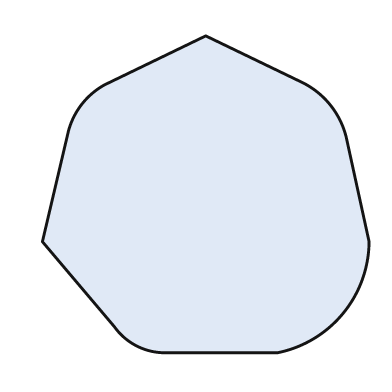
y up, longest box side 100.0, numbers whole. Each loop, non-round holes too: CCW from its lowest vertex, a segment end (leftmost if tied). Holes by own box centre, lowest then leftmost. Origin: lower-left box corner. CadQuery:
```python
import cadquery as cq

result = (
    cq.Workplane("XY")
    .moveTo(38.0, 0.0)
    .lineTo(72.0, 0.0)
    .threePointArc((92.0, 12.0), (100.0, 34.0))
    .lineTo(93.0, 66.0)
    .threePointArc((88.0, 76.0), (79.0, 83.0))
    .lineTo(50.0, 97.0)
    .lineTo(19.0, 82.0)
    .threePointArc((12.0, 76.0), (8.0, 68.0))
    .lineTo(0.0, 34.0)
    .lineTo(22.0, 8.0)
    .threePointArc((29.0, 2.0), (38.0, 0.0))
    .close()
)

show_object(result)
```